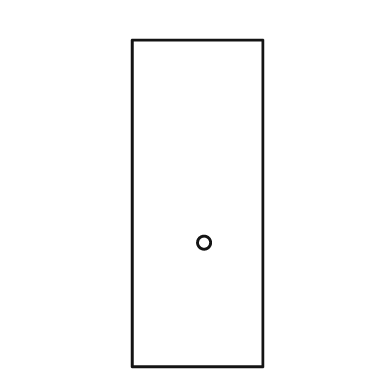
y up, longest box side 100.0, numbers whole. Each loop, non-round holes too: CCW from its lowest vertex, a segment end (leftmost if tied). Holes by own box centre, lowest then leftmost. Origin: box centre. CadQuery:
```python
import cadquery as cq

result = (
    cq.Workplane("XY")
    .moveTo(-20.0, -50.0)
    .lineTo(20.0, -50.0)
    .lineTo(20.0, 50.0)
    .lineTo(-20.0, 50.0)
    .close()
    .moveTo(2.0, -12.0)
    .circle(2.0)
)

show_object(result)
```